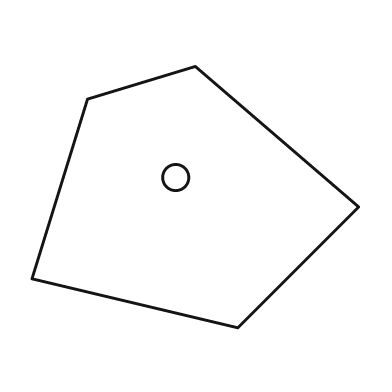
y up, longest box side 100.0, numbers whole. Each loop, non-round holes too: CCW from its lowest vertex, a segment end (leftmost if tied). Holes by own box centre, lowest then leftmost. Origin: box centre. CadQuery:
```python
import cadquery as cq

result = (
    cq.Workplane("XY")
    .moveTo(13.0, -40.0)
    .lineTo(50.0, -3.0)
    .lineTo(0.0, 40.0)
    .lineTo(-33.0, 30.0)
    .lineTo(-50.0, -25.0)
    .close()
    .moveTo(-6.0, 6.0)
    .circle(4.0)
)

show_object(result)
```